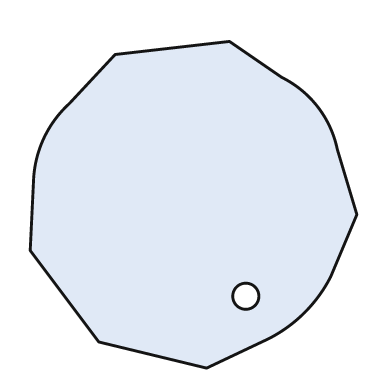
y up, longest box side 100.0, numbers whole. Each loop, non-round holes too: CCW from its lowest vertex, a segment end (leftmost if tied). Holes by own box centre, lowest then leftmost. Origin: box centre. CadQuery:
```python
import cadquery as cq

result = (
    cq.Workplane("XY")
    .moveTo(4.0, -50.0)
    .lineTo(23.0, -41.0)
    .threePointArc((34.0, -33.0), (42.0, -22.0))
    .lineTo(50.0, -3.0)
    .lineTo(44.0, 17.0)
    .threePointArc((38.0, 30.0), (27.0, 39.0))
    .lineTo(11.0, 50.0)
    .lineTo(-24.0, 46.0)
    .lineTo(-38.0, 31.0)
    .threePointArc((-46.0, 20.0), (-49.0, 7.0))
    .lineTo(-50.0, -14.0)
    .lineTo(-29.0, -42.0)
    .close()
    .moveTo(16.0, -28.0)
    .circle(4.0)
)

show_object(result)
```